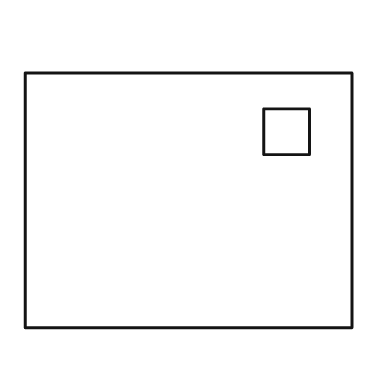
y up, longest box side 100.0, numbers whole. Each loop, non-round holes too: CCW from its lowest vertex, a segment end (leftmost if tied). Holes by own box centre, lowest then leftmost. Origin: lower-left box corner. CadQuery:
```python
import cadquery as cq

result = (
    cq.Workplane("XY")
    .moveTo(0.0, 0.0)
    .lineTo(100.0, 0.0)
    .lineTo(100.0, 78.0)
    .lineTo(0.0, 78.0)
    .close()
    .moveTo(73.0, 53.0)
    .lineTo(87.0, 53.0)
    .lineTo(87.0, 67.0)
    .lineTo(73.0, 67.0)
    .close()
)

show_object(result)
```